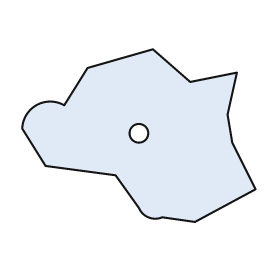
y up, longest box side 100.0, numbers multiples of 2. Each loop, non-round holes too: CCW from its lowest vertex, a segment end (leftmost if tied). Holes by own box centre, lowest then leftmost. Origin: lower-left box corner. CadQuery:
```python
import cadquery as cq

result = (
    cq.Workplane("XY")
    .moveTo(74.0, 0.0)
    .lineTo(100.0, 14.0)
    .lineTo(90.0, 34.0)
    .lineTo(88.0, 46.0)
    .lineTo(92.0, 64.0)
    .lineTo(72.0, 60.0)
    .lineTo(56.0, 74.0)
    .lineTo(28.0, 66.0)
    .lineTo(18.0, 50.0)
    .threePointArc((6.0, 50.0), (0.0, 40.0))
    .lineTo(10.0, 24.0)
    .lineTo(40.0, 20.0)
    .lineTo(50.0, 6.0)
    .threePointArc((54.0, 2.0), (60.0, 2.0))
    .close()
    .moveTo(50.0, 38.0)
    .circle(4.0)
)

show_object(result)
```